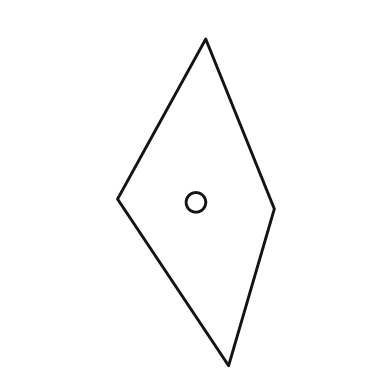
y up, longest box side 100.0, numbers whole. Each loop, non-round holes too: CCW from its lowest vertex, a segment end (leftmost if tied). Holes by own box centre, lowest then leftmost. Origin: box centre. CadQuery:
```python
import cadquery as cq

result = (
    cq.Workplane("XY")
    .moveTo(10.0, -50.0)
    .lineTo(24.0, -2.0)
    .lineTo(3.0, 50.0)
    .lineTo(-24.0, 1.0)
    .close()
    .moveTo(0.0, 0.0)
    .circle(3.0)
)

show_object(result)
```